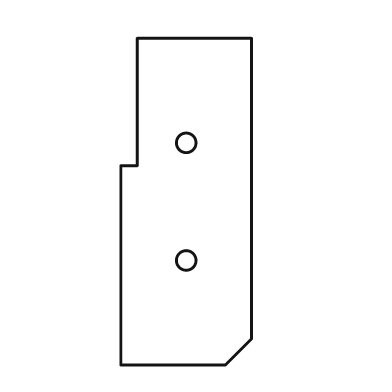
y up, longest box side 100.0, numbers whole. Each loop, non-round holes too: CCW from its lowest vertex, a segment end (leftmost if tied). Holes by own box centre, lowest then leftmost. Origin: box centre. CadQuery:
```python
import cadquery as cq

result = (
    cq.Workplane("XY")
    .moveTo(-20.0, -50.0)
    .lineTo(12.0, -50.0)
    .lineTo(20.0, -42.0)
    .lineTo(20.0, 50.0)
    .lineTo(-15.0, 50.0)
    .lineTo(-15.0, 11.0)
    .lineTo(-20.0, 11.0)
    .close()
    .moveTo(0.0, -18.0)
    .circle(3.0)
    .moveTo(0.0, 18.0)
    .circle(3.0)
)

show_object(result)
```